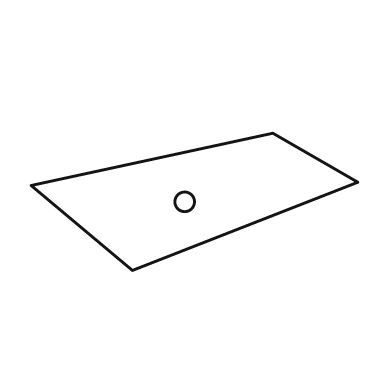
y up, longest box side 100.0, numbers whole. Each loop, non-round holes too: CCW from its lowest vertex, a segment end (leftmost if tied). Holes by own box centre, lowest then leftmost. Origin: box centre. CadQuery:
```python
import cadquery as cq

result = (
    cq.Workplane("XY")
    .moveTo(-19.0, -21.0)
    .lineTo(50.0, 6.0)
    .lineTo(24.0, 21.0)
    .lineTo(-50.0, 5.0)
    .close()
    .moveTo(-3.0, 0.0)
    .circle(3.0)
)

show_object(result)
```